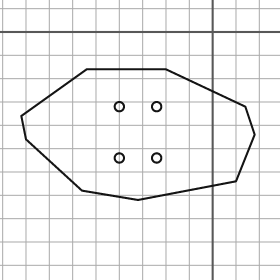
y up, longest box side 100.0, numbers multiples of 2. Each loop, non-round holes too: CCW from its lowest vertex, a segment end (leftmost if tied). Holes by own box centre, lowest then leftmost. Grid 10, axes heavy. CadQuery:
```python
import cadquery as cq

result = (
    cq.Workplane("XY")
    .moveTo(-32.0, -72.0)
    .lineTo(10.0, -64.0)
    .lineTo(18.0, -44.0)
    .lineTo(14.0, -32.0)
    .lineTo(-20.0, -16.0)
    .lineTo(-54.0, -16.0)
    .lineTo(-82.0, -36.0)
    .lineTo(-80.0, -46.0)
    .lineTo(-56.0, -68.0)
    .close()
    .moveTo(-40.0, -54.0)
    .circle(2.0)
    .moveTo(-24.0, -54.0)
    .circle(2.0)
    .moveTo(-40.0, -32.0)
    .circle(2.0)
    .moveTo(-24.0, -32.0)
    .circle(2.0)
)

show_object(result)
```